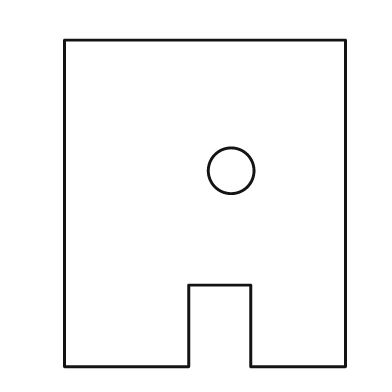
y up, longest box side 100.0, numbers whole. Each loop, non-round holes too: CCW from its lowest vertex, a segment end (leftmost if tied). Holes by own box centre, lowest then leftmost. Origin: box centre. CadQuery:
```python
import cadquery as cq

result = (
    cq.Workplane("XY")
    .moveTo(-43.0, -50.0)
    .lineTo(-5.0, -50.0)
    .lineTo(-5.0, -25.0)
    .lineTo(14.0, -25.0)
    .lineTo(14.0, -50.0)
    .lineTo(43.0, -50.0)
    .lineTo(43.0, 50.0)
    .lineTo(-43.0, 50.0)
    .close()
    .moveTo(8.0, 10.0)
    .circle(7.0)
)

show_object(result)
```